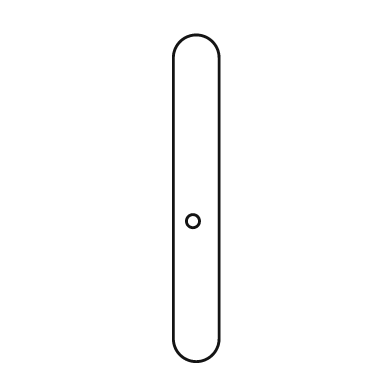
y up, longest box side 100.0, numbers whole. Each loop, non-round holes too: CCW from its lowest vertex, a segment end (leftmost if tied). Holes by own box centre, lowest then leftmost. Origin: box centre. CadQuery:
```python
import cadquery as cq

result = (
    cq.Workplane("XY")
    .moveTo(-7.0, -43.0)
    .threePointArc((0.0, -50.0), (7.0, -43.0))
    .lineTo(7.0, 43.0)
    .threePointArc((0.0, 50.0), (-7.0, 43.0))
    .close()
    .moveTo(-1.0, -7.0)
    .circle(2.0)
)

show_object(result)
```